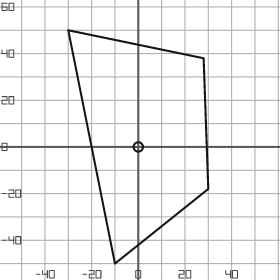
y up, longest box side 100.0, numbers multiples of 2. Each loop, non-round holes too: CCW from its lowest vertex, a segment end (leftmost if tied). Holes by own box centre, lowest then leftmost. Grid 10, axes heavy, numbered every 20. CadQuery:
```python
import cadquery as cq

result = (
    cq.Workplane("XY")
    .moveTo(-10.0, -50.0)
    .lineTo(30.0, -18.0)
    .lineTo(28.0, 38.0)
    .lineTo(-30.0, 50.0)
    .close()
    .moveTo(0.0, 0.0)
    .circle(2.0)
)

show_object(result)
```